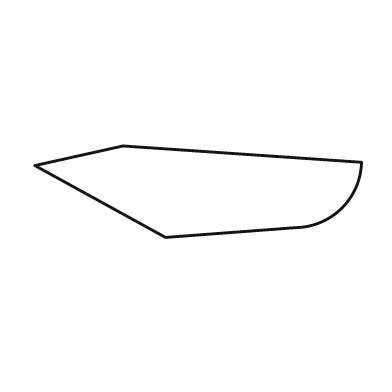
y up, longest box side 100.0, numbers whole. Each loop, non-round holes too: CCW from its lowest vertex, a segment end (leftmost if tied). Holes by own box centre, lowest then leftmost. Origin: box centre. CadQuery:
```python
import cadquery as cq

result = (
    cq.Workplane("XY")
    .moveTo(-10.0, -14.0)
    .lineTo(30.0, -11.0)
    .threePointArc((44.0, -5.0), (50.0, 9.0))
    .lineTo(-23.0, 14.0)
    .lineTo(-50.0, 8.0)
    .close()
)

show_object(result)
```